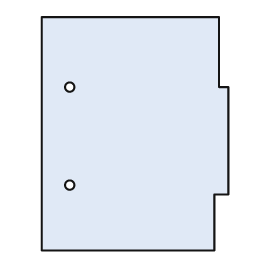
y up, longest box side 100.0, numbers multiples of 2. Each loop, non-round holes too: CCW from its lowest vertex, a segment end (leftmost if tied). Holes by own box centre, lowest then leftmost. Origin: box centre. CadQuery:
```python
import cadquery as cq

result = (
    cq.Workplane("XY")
    .moveTo(-40.0, -50.0)
    .lineTo(34.0, -50.0)
    .lineTo(34.0, -26.0)
    .lineTo(40.0, -26.0)
    .lineTo(40.0, 20.0)
    .lineTo(36.0, 20.0)
    .lineTo(36.0, 50.0)
    .lineTo(-40.0, 50.0)
    .close()
    .moveTo(-28.0, -22.0)
    .circle(2.0)
    .moveTo(-28.0, 20.0)
    .circle(2.0)
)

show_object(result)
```